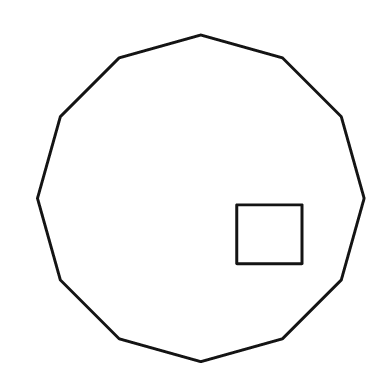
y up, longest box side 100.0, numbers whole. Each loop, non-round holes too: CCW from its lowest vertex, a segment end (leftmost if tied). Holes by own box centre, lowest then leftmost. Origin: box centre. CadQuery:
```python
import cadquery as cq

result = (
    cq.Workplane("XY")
    .moveTo(0.0, -50.0)
    .lineTo(25.0, -43.0)
    .lineTo(43.0, -25.0)
    .lineTo(50.0, 0.0)
    .lineTo(43.0, 25.0)
    .lineTo(25.0, 43.0)
    .lineTo(0.0, 50.0)
    .lineTo(-25.0, 43.0)
    .lineTo(-43.0, 25.0)
    .lineTo(-50.0, 0.0)
    .lineTo(-43.0, -25.0)
    .lineTo(-25.0, -43.0)
    .close()
    .moveTo(11.0, -20.0)
    .lineTo(31.0, -20.0)
    .lineTo(31.0, -2.0)
    .lineTo(11.0, -2.0)
    .close()
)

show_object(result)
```